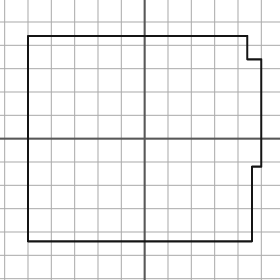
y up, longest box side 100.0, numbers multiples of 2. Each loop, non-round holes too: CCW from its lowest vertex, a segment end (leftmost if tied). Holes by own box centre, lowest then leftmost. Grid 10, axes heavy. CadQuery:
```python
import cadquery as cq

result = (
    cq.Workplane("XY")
    .moveTo(-50.0, -44.0)
    .lineTo(46.0, -44.0)
    .lineTo(46.0, -12.0)
    .lineTo(50.0, -12.0)
    .lineTo(50.0, 34.0)
    .lineTo(44.0, 34.0)
    .lineTo(44.0, 44.0)
    .lineTo(-50.0, 44.0)
    .close()
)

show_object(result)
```